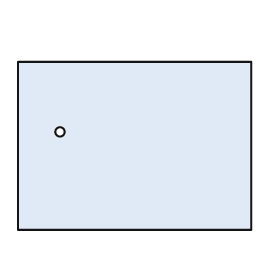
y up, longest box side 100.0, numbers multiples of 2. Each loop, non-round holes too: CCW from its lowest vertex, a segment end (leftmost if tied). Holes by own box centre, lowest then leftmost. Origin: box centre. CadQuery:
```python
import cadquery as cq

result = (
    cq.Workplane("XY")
    .moveTo(-50.0, -36.0)
    .lineTo(50.0, -36.0)
    .lineTo(50.0, 36.0)
    .lineTo(-50.0, 36.0)
    .close()
    .moveTo(-32.0, 6.0)
    .circle(2.0)
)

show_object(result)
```